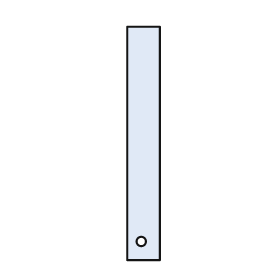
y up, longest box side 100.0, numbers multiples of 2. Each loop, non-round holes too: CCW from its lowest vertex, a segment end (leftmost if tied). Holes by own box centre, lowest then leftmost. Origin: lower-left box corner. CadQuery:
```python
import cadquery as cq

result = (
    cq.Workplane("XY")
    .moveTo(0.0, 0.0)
    .lineTo(14.0, 0.0)
    .lineTo(14.0, 100.0)
    .lineTo(0.0, 100.0)
    .close()
    .moveTo(6.0, 8.0)
    .circle(2.0)
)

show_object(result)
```